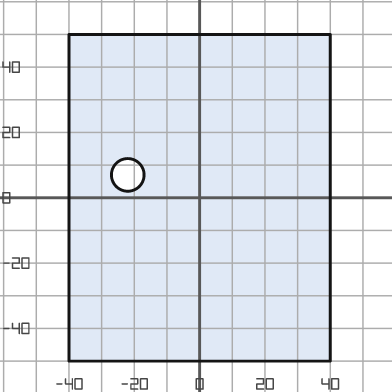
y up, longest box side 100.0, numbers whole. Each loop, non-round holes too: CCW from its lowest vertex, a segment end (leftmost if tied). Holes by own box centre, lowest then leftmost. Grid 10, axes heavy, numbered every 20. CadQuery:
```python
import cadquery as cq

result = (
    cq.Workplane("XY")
    .moveTo(-40.0, -50.0)
    .lineTo(40.0, -50.0)
    .lineTo(40.0, 50.0)
    .lineTo(-40.0, 50.0)
    .close()
    .moveTo(-22.0, 7.0)
    .circle(5.0)
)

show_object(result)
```